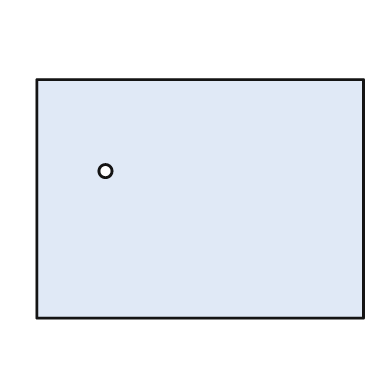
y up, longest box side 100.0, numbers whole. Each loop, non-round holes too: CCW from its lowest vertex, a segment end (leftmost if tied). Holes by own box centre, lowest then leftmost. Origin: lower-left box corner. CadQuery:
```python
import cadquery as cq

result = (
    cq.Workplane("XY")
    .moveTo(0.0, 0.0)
    .lineTo(100.0, 0.0)
    .lineTo(100.0, 73.0)
    .lineTo(0.0, 73.0)
    .close()
    .moveTo(21.0, 45.0)
    .circle(2.0)
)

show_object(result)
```